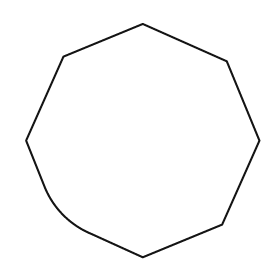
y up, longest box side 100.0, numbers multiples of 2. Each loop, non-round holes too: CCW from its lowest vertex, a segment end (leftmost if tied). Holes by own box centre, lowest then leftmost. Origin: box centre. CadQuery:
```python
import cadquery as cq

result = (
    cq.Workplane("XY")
    .moveTo(0.0, -50.0)
    .lineTo(34.0, -36.0)
    .lineTo(50.0, 0.0)
    .lineTo(36.0, 34.0)
    .lineTo(0.0, 50.0)
    .lineTo(-34.0, 36.0)
    .lineTo(-50.0, 0.0)
    .lineTo(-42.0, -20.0)
    .threePointArc((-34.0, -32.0), (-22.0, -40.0))
    .close()
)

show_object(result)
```